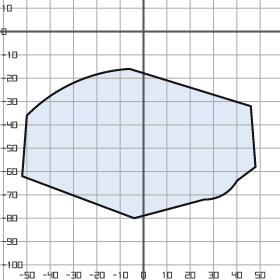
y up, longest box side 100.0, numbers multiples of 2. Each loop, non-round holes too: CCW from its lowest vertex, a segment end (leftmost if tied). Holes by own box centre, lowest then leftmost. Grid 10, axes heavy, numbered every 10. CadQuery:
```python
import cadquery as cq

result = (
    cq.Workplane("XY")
    .moveTo(-4.0, -80.0)
    .lineTo(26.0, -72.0)
    .threePointArc((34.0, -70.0), (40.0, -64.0))
    .lineTo(48.0, -58.0)
    .lineTo(46.0, -32.0)
    .lineTo(-6.0, -16.0)
    .threePointArc((-30.0, -22.0), (-50.0, -36.0))
    .lineTo(-52.0, -62.0)
    .close()
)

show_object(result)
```